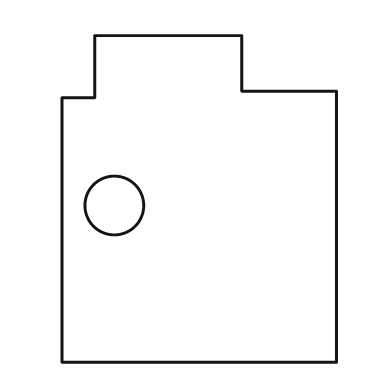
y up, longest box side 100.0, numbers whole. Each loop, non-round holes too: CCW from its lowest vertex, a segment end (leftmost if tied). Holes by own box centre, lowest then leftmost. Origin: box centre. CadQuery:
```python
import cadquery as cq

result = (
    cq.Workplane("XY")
    .moveTo(-42.0, -50.0)
    .lineTo(42.0, -50.0)
    .lineTo(42.0, 33.0)
    .lineTo(13.0, 33.0)
    .lineTo(13.0, 50.0)
    .lineTo(-32.0, 50.0)
    .lineTo(-32.0, 31.0)
    .lineTo(-42.0, 31.0)
    .close()
    .moveTo(-26.0, -2.0)
    .circle(9.0)
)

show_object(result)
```